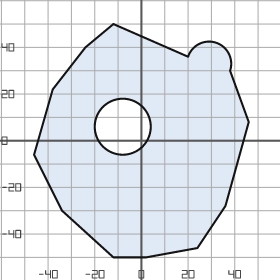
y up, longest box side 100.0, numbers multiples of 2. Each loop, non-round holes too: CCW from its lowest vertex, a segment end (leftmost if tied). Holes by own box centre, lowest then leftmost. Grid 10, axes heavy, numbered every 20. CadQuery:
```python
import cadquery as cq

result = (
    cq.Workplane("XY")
    .moveTo(-12.0, -50.0)
    .lineTo(2.0, -50.0)
    .lineTo(24.0, -46.0)
    .lineTo(36.0, -28.0)
    .lineTo(46.0, 8.0)
    .lineTo(38.0, 30.0)
    .threePointArc((32.0, 42.0), (20.0, 36.0))
    .lineTo(-12.0, 50.0)
    .lineTo(-24.0, 40.0)
    .lineTo(-38.0, 22.0)
    .lineTo(-46.0, -6.0)
    .lineTo(-34.0, -30.0)
    .close()
    .moveTo(-8.0, 6.0)
    .circle(12.0)
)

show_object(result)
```